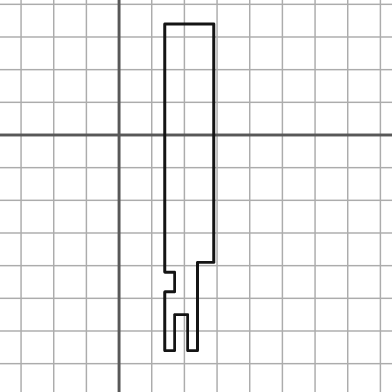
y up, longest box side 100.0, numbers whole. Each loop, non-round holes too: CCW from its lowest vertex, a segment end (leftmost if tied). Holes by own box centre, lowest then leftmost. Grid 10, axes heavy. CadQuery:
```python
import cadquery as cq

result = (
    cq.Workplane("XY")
    .moveTo(14.0, -66.0)
    .lineTo(17.0, -66.0)
    .lineTo(17.0, -55.0)
    .lineTo(21.0, -55.0)
    .lineTo(21.0, -66.0)
    .lineTo(24.0, -66.0)
    .lineTo(24.0, -39.0)
    .lineTo(29.0, -39.0)
    .lineTo(29.0, 34.0)
    .lineTo(14.0, 34.0)
    .lineTo(14.0, -42.0)
    .lineTo(17.0, -42.0)
    .lineTo(17.0, -48.0)
    .lineTo(14.0, -48.0)
    .close()
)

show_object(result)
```